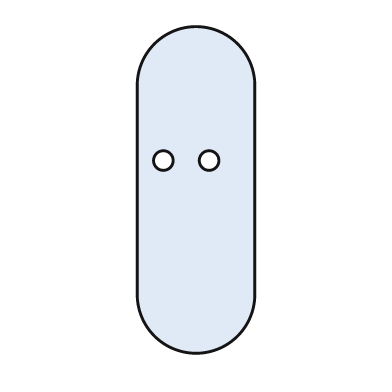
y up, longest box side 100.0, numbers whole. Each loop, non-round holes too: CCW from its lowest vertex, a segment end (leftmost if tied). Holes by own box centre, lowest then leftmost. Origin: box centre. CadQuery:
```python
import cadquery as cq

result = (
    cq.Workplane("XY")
    .moveTo(-18.0, -32.0)
    .threePointArc((0.0, -50.0), (18.0, -32.0))
    .lineTo(18.0, 32.0)
    .threePointArc((0.0, 50.0), (-18.0, 32.0))
    .close()
    .moveTo(-10.0, 9.0)
    .circle(3.0)
    .moveTo(4.0, 9.0)
    .circle(3.0)
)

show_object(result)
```